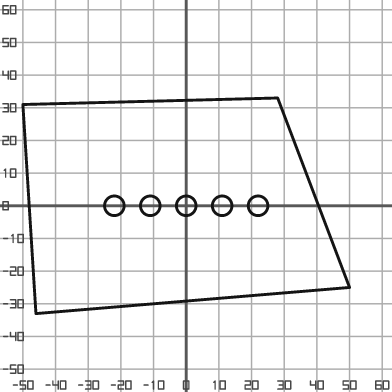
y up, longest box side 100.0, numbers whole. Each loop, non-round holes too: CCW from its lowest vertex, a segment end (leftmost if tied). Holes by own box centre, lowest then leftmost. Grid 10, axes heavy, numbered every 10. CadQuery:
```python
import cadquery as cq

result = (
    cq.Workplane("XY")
    .moveTo(-46.0, -33.0)
    .lineTo(50.0, -25.0)
    .lineTo(28.0, 33.0)
    .lineTo(-50.0, 31.0)
    .close()
    .moveTo(-22.0, 0.0)
    .circle(3.0)
    .moveTo(-11.0, 0.0)
    .circle(3.0)
    .moveTo(0.0, 0.0)
    .circle(3.0)
    .moveTo(11.0, 0.0)
    .circle(3.0)
    .moveTo(22.0, 0.0)
    .circle(3.0)
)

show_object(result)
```